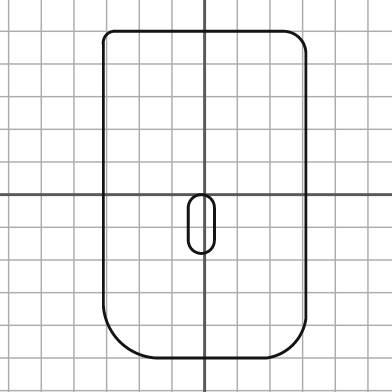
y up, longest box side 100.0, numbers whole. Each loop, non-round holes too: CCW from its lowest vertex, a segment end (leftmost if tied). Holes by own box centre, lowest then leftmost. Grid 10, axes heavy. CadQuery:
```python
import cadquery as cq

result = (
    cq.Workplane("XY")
    .moveTo(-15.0, -50.0)
    .lineTo(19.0, -50.0)
    .threePointArc((27.0, -46.0), (31.0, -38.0))
    .lineTo(31.0, 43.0)
    .threePointArc((29.0, 48.0), (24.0, 50.0))
    .lineTo(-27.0, 50.0)
    .threePointArc((-30.0, 49.0), (-31.0, 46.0))
    .lineTo(-31.0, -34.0)
    .threePointArc((-26.0, -45.0), (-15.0, -50.0))
    .close()
    .moveTo(-5.0, -14.0)
    .threePointArc((-1.0, -18.0), (3.0, -14.0))
    .lineTo(3.0, -4.0)
    .threePointArc((-1.0, 0.0), (-5.0, -4.0))
    .close()
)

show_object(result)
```